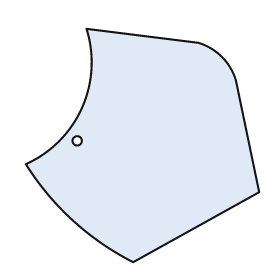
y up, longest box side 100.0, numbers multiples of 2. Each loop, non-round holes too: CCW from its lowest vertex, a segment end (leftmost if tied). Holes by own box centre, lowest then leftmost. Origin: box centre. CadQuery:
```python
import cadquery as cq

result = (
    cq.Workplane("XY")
    .moveTo(-4.0, -50.0)
    .lineTo(50.0, -20.0)
    .lineTo(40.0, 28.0)
    .threePointArc((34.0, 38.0), (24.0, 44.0))
    .lineTo(-24.0, 50.0)
    .threePointArc((-26.0, 16.0), (-50.0, -8.0))
    .threePointArc((-30.0, -32.0), (-4.0, -50.0))
    .close()
    .moveTo(-28.0, 2.0)
    .circle(2.0)
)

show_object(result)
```